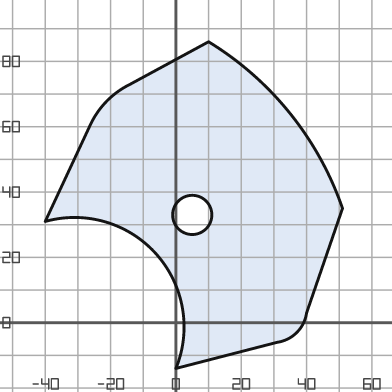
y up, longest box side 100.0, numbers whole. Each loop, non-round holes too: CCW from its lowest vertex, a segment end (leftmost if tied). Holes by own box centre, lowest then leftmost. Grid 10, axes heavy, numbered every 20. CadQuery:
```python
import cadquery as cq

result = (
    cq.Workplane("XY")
    .moveTo(0.0, -14.0)
    .lineTo(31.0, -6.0)
    .threePointArc((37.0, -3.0), (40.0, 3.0))
    .lineTo(51.0, 35.0)
    .threePointArc((35.0, 64.0), (10.0, 86.0))
    .lineTo(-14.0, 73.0)
    .threePointArc((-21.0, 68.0), (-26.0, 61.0))
    .lineTo(-40.0, 31.0)
    .threePointArc((-6.0, 21.0), (0.0, -14.0))
    .close()
    .moveTo(5.0, 33.0)
    .circle(6.0)
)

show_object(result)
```